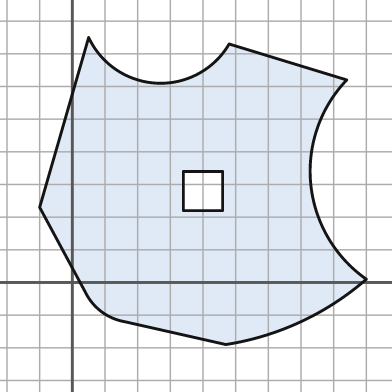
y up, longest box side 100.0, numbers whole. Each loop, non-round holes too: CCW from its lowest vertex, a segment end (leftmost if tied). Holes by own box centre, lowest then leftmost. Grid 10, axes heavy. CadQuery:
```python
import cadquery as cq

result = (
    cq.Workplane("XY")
    .moveTo(47.0, -19.0)
    .threePointArc((70.0, -12.0), (90.0, 1.0))
    .threePointArc((73.0, 30.0), (84.0, 62.0))
    .lineTo(48.0, 73.0)
    .threePointArc((26.0, 61.0), (5.0, 75.0))
    .lineTo(-10.0, 23.0)
    .lineTo(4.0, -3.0)
    .threePointArc((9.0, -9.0), (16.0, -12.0))
    .close()
    .moveTo(34.0, 22.0)
    .lineTo(46.0, 22.0)
    .lineTo(46.0, 34.0)
    .lineTo(34.0, 34.0)
    .close()
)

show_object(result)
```